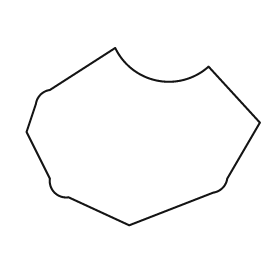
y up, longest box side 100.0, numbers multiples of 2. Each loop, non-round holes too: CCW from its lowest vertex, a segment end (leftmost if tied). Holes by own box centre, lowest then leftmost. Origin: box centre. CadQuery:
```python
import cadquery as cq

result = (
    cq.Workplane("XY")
    .moveTo(-6.0, -38.0)
    .lineTo(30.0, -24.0)
    .threePointArc((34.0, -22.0), (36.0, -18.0))
    .lineTo(50.0, 6.0)
    .lineTo(28.0, 30.0)
    .threePointArc((6.0, 24.0), (-12.0, 38.0))
    .lineTo(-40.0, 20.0)
    .threePointArc((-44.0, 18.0), (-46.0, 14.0))
    .lineTo(-50.0, 2.0)
    .lineTo(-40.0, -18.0)
    .threePointArc((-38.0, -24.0), (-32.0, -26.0))
    .close()
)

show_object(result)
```